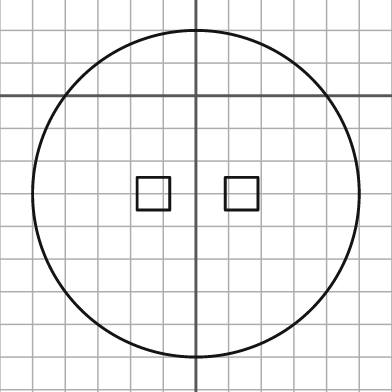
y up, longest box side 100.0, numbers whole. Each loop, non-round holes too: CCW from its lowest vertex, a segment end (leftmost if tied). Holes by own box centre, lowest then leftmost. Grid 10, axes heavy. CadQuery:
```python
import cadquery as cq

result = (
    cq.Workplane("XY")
    .moveTo(0.0, -30.0)
    .circle(50.0)
    .moveTo(-18.0, -35.0)
    .lineTo(-8.0, -35.0)
    .lineTo(-8.0, -25.0)
    .lineTo(-18.0, -25.0)
    .close()
    .moveTo(9.0, -35.0)
    .lineTo(19.0, -35.0)
    .lineTo(19.0, -25.0)
    .lineTo(9.0, -25.0)
    .close()
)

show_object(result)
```